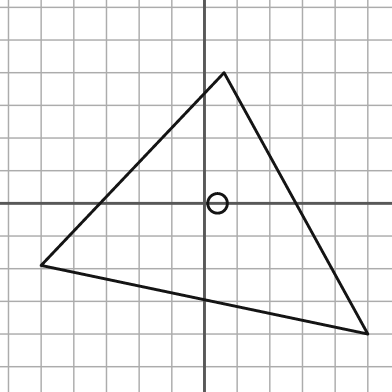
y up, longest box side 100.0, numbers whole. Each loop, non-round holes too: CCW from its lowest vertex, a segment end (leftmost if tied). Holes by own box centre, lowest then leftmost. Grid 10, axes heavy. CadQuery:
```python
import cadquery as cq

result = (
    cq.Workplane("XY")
    .moveTo(50.0, -40.0)
    .lineTo(6.0, 40.0)
    .lineTo(-50.0, -19.0)
    .close()
    .moveTo(4.0, 0.0)
    .circle(3.0)
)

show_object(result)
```